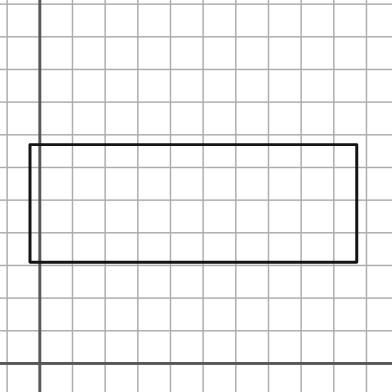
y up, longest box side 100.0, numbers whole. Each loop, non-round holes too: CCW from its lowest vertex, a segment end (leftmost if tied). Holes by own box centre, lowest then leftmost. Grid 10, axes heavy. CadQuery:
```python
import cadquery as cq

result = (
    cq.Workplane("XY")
    .moveTo(-3.0, 31.0)
    .lineTo(97.0, 31.0)
    .lineTo(97.0, 67.0)
    .lineTo(-3.0, 67.0)
    .close()
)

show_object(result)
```